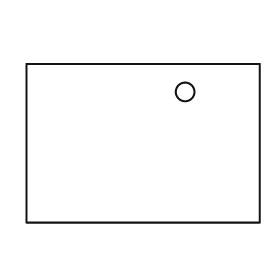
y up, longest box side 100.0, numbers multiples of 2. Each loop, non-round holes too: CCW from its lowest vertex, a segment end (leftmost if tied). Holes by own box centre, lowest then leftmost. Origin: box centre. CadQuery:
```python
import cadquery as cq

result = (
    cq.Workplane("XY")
    .moveTo(-50.0, -34.0)
    .lineTo(50.0, -34.0)
    .lineTo(50.0, 34.0)
    .lineTo(-50.0, 34.0)
    .close()
    .moveTo(18.0, 22.0)
    .circle(4.0)
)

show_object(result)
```